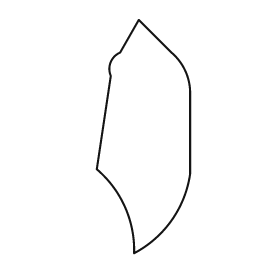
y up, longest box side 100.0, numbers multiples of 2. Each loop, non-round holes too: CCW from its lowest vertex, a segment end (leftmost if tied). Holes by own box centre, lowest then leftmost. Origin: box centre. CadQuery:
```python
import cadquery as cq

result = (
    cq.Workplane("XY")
    .moveTo(-4.0, -50.0)
    .threePointArc((12.0, -36.0), (20.0, -16.0))
    .lineTo(20.0, 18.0)
    .threePointArc((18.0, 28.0), (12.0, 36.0))
    .lineTo(-2.0, 50.0)
    .lineTo(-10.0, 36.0)
    .threePointArc((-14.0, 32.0), (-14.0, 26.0))
    .lineTo(-20.0, -14.0)
    .threePointArc((-8.0, -30.0), (-4.0, -50.0))
    .close()
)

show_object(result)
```